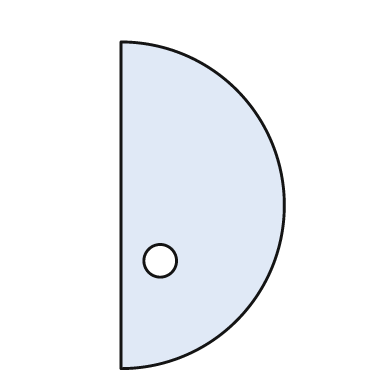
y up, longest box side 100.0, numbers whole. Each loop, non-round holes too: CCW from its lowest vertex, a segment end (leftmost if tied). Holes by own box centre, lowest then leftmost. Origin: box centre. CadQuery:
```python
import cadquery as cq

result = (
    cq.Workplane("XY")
    .moveTo(-25.0, -50.0)
    .threePointArc((25.0, 0.0), (-25.0, 50.0))
    .close()
    .moveTo(-13.0, -17.0)
    .circle(5.0)
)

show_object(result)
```